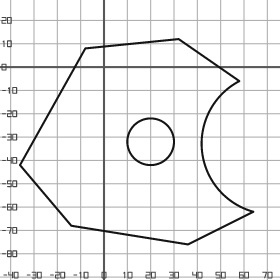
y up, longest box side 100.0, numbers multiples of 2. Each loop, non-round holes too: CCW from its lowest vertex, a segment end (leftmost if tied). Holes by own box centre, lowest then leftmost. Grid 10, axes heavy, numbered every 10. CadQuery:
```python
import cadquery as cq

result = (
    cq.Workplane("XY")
    .moveTo(36.0, -76.0)
    .lineTo(64.0, -62.0)
    .threePointArc((42.0, -36.0), (58.0, -6.0))
    .lineTo(32.0, 12.0)
    .lineTo(-8.0, 8.0)
    .lineTo(-36.0, -42.0)
    .lineTo(-14.0, -68.0)
    .close()
    .moveTo(20.0, -32.0)
    .circle(10.0)
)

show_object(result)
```